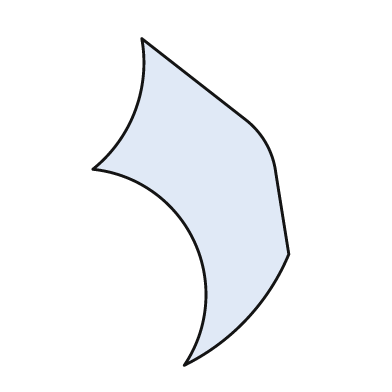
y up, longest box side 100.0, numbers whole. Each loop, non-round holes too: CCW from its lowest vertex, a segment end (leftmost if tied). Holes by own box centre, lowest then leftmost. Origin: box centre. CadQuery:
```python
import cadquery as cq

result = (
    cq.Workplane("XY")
    .moveTo(-2.0, -50.0)
    .threePointArc((17.0, -36.0), (30.0, -16.0))
    .lineTo(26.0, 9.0)
    .threePointArc((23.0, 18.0), (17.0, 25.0))
    .lineTo(-15.0, 50.0)
    .threePointArc((-17.0, 28.0), (-30.0, 10.0))
    .threePointArc((1.0, -12.0), (-2.0, -50.0))
    .close()
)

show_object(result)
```